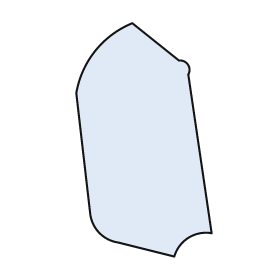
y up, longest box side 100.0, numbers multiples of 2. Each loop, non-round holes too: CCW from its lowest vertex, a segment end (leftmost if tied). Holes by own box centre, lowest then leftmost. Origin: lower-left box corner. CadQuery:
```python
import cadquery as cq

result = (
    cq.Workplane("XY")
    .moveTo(42.0, 0.0)
    .threePointArc((48.0, 8.0), (58.0, 10.0))
    .lineTo(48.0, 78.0)
    .threePointArc((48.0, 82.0), (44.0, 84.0))
    .lineTo(24.0, 100.0)
    .threePointArc((8.0, 88.0), (0.0, 70.0))
    .lineTo(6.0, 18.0)
    .threePointArc((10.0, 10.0), (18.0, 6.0))
    .close()
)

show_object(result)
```